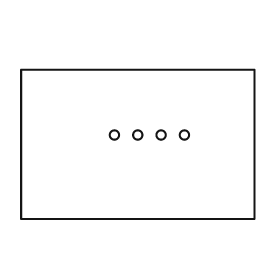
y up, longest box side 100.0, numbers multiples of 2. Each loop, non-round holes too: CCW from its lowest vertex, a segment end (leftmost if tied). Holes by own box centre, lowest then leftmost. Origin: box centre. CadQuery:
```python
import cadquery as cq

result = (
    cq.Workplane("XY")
    .moveTo(-50.0, -32.0)
    .lineTo(50.0, -32.0)
    .lineTo(50.0, 32.0)
    .lineTo(-50.0, 32.0)
    .close()
    .moveTo(-10.0, 4.0)
    .circle(2.0)
    .moveTo(0.0, 4.0)
    .circle(2.0)
    .moveTo(10.0, 4.0)
    .circle(2.0)
    .moveTo(20.0, 4.0)
    .circle(2.0)
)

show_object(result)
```